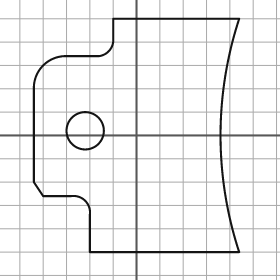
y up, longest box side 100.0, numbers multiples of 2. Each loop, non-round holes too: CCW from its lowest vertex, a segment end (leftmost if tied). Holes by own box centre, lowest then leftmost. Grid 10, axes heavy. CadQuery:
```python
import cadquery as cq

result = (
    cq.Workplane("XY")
    .moveTo(-20.0, -50.0)
    .lineTo(44.0, -50.0)
    .threePointArc((36.0, 0.0), (44.0, 50.0))
    .lineTo(-10.0, 50.0)
    .lineTo(-10.0, 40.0)
    .threePointArc((-12.0, 36.0), (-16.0, 34.0))
    .lineTo(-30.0, 34.0)
    .threePointArc((-40.0, 30.0), (-44.0, 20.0))
    .lineTo(-44.0, -20.0)
    .lineTo(-40.0, -26.0)
    .lineTo(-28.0, -26.0)
    .threePointArc((-22.0, -28.0), (-20.0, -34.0))
    .close()
    .moveTo(-22.0, 2.0)
    .circle(8.0)
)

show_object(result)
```